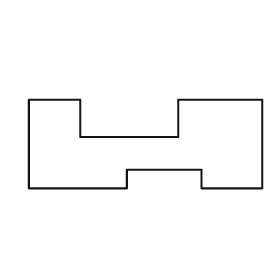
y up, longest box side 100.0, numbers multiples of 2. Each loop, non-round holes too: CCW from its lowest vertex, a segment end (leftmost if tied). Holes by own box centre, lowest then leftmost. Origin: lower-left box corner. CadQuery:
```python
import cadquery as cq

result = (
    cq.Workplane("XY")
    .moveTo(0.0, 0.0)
    .lineTo(42.0, 0.0)
    .lineTo(42.0, 8.0)
    .lineTo(74.0, 8.0)
    .lineTo(74.0, 0.0)
    .lineTo(100.0, 0.0)
    .lineTo(100.0, 38.0)
    .lineTo(64.0, 38.0)
    .lineTo(64.0, 22.0)
    .lineTo(22.0, 22.0)
    .lineTo(22.0, 38.0)
    .lineTo(0.0, 38.0)
    .close()
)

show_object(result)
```